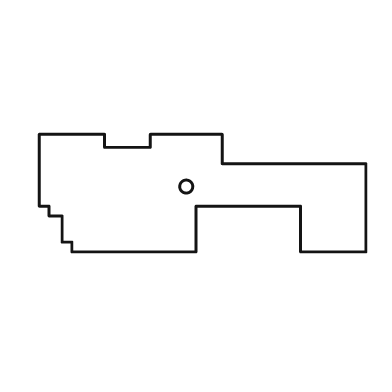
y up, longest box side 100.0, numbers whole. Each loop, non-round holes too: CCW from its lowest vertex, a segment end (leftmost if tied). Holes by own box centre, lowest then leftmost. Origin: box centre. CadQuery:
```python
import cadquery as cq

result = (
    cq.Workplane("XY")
    .moveTo(-40.0, -18.0)
    .lineTo(-2.0, -18.0)
    .lineTo(-2.0, -4.0)
    .lineTo(30.0, -4.0)
    .lineTo(30.0, -18.0)
    .lineTo(50.0, -18.0)
    .lineTo(50.0, 9.0)
    .lineTo(6.0, 9.0)
    .lineTo(6.0, 18.0)
    .lineTo(-16.0, 18.0)
    .lineTo(-16.0, 14.0)
    .lineTo(-30.0, 14.0)
    .lineTo(-30.0, 18.0)
    .lineTo(-50.0, 18.0)
    .lineTo(-50.0, -4.0)
    .lineTo(-47.0, -4.0)
    .lineTo(-47.0, -7.0)
    .lineTo(-43.0, -7.0)
    .lineTo(-43.0, -15.0)
    .lineTo(-40.0, -15.0)
    .close()
    .moveTo(-5.0, 2.0)
    .circle(2.0)
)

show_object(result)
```